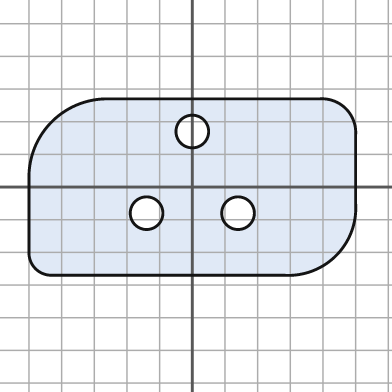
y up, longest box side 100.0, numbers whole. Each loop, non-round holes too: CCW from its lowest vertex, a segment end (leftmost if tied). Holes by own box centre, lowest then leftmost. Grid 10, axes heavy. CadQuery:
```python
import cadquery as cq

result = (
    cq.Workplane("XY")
    .moveTo(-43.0, -27.0)
    .lineTo(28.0, -27.0)
    .threePointArc((44.0, -21.0), (50.0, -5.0))
    .lineTo(50.0, 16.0)
    .threePointArc((47.0, 24.0), (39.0, 27.0))
    .lineTo(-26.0, 27.0)
    .threePointArc((-43.0, 20.0), (-50.0, 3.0))
    .lineTo(-50.0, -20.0)
    .threePointArc((-48.0, -25.0), (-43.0, -27.0))
    .close()
    .moveTo(-14.0, -8.0)
    .circle(5.0)
    .moveTo(14.0, -8.0)
    .circle(5.0)
    .moveTo(0.0, 17.0)
    .circle(5.0)
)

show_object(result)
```